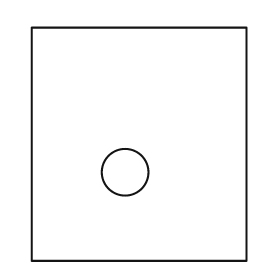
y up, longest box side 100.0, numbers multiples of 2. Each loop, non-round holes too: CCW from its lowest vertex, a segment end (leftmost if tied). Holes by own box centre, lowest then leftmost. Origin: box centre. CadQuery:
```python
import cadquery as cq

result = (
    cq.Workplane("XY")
    .moveTo(-46.0, -50.0)
    .lineTo(46.0, -50.0)
    .lineTo(46.0, 50.0)
    .lineTo(-46.0, 50.0)
    .close()
    .moveTo(-6.0, -12.0)
    .circle(10.0)
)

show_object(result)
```